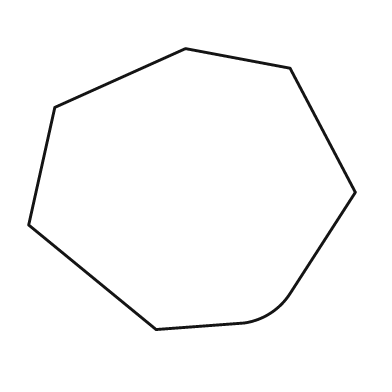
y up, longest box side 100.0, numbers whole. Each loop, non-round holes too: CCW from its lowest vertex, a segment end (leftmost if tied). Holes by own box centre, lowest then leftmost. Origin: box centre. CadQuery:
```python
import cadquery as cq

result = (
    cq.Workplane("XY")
    .moveTo(-11.0, -43.0)
    .lineTo(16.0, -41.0)
    .threePointArc((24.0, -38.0), (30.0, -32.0))
    .lineTo(50.0, -1.0)
    .lineTo(30.0, 37.0)
    .lineTo(-2.0, 43.0)
    .lineTo(-42.0, 25.0)
    .lineTo(-50.0, -11.0)
    .close()
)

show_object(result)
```